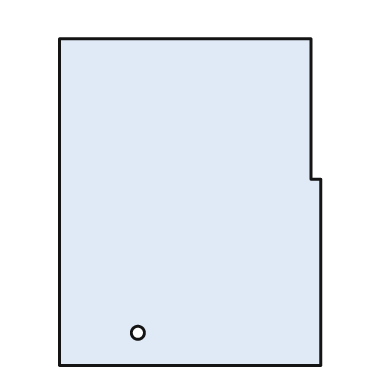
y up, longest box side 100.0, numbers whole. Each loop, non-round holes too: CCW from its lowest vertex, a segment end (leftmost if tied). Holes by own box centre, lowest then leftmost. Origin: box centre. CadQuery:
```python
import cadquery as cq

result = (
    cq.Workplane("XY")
    .moveTo(-40.0, -50.0)
    .lineTo(40.0, -50.0)
    .lineTo(40.0, 7.0)
    .lineTo(37.0, 7.0)
    .lineTo(37.0, 50.0)
    .lineTo(-40.0, 50.0)
    .close()
    .moveTo(-16.0, -40.0)
    .circle(2.0)
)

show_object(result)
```